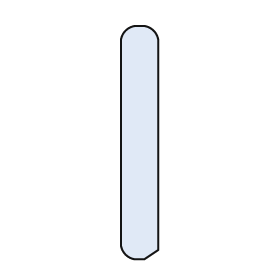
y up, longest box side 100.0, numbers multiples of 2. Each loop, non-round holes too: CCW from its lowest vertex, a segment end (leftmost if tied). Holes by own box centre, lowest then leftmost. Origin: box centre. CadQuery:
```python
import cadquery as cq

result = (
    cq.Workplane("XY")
    .moveTo(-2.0, -50.0)
    .lineTo(2.0, -50.0)
    .lineTo(8.0, -46.0)
    .lineTo(8.0, 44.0)
    .threePointArc((6.0, 48.0), (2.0, 50.0))
    .lineTo(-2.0, 50.0)
    .threePointArc((-6.0, 48.0), (-8.0, 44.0))
    .lineTo(-8.0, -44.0)
    .threePointArc((-6.0, -48.0), (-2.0, -50.0))
    .close()
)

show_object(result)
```